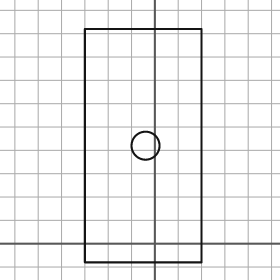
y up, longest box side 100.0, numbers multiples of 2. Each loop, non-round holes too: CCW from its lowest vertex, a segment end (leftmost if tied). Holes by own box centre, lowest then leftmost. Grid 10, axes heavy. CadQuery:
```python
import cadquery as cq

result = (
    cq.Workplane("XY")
    .moveTo(-30.0, -8.0)
    .lineTo(20.0, -8.0)
    .lineTo(20.0, 92.0)
    .lineTo(-30.0, 92.0)
    .close()
    .moveTo(-4.0, 42.0)
    .circle(6.0)
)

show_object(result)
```